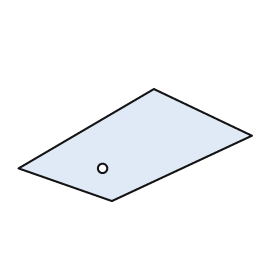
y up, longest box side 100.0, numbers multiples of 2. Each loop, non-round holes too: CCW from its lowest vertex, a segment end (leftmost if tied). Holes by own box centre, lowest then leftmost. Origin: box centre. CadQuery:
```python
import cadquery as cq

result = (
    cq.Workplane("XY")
    .moveTo(-10.0, -24.0)
    .lineTo(50.0, 4.0)
    .lineTo(8.0, 24.0)
    .lineTo(-50.0, -10.0)
    .close()
    .moveTo(-14.0, -10.0)
    .circle(2.0)
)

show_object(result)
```